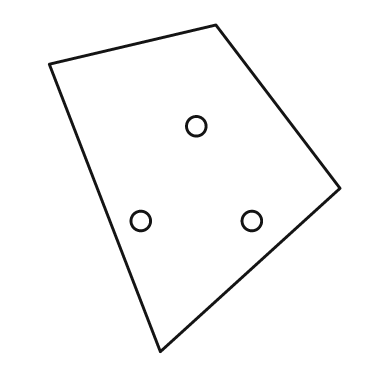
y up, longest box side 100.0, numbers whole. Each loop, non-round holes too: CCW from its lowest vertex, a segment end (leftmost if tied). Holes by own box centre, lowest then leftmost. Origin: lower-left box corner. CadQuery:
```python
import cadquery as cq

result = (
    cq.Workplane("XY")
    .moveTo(34.0, 0.0)
    .lineTo(89.0, 50.0)
    .lineTo(51.0, 100.0)
    .lineTo(0.0, 88.0)
    .close()
    .moveTo(28.0, 40.0)
    .circle(3.0)
    .moveTo(62.0, 40.0)
    .circle(3.0)
    .moveTo(45.0, 69.0)
    .circle(3.0)
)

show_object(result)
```